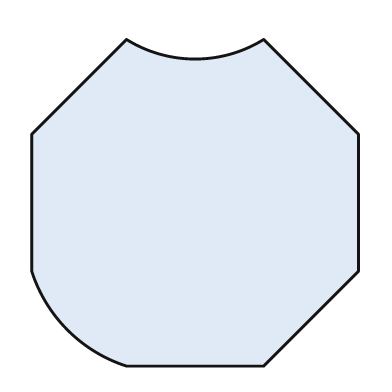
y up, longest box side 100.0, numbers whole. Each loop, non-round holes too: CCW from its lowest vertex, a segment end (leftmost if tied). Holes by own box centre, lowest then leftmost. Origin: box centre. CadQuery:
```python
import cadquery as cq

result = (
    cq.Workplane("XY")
    .moveTo(-21.0, -50.0)
    .lineTo(21.0, -50.0)
    .lineTo(50.0, -21.0)
    .lineTo(50.0, 21.0)
    .lineTo(21.0, 50.0)
    .threePointArc((0.0, 44.0), (-21.0, 50.0))
    .lineTo(-50.0, 21.0)
    .lineTo(-50.0, -21.0)
    .threePointArc((-39.0, -39.0), (-21.0, -50.0))
    .close()
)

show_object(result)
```